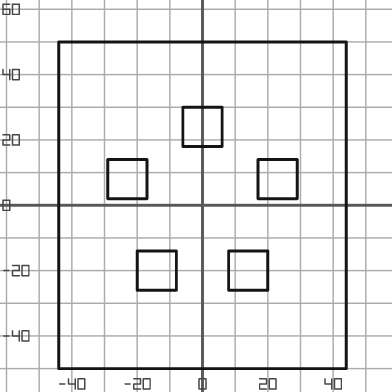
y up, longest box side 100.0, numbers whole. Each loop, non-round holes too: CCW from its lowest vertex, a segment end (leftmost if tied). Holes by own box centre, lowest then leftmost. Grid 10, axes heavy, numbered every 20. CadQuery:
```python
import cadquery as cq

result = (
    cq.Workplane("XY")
    .moveTo(-44.0, -50.0)
    .lineTo(44.0, -50.0)
    .lineTo(44.0, 50.0)
    .lineTo(-44.0, 50.0)
    .close()
    .moveTo(-20.0, -26.0)
    .lineTo(-8.0, -26.0)
    .lineTo(-8.0, -14.0)
    .lineTo(-20.0, -14.0)
    .close()
    .moveTo(8.0, -26.0)
    .lineTo(20.0, -26.0)
    .lineTo(20.0, -14.0)
    .lineTo(8.0, -14.0)
    .close()
    .moveTo(-29.0, 2.0)
    .lineTo(-17.0, 2.0)
    .lineTo(-17.0, 14.0)
    .lineTo(-29.0, 14.0)
    .close()
    .moveTo(17.0, 2.0)
    .lineTo(29.0, 2.0)
    .lineTo(29.0, 14.0)
    .lineTo(17.0, 14.0)
    .close()
    .moveTo(-6.0, 18.0)
    .lineTo(6.0, 18.0)
    .lineTo(6.0, 30.0)
    .lineTo(-6.0, 30.0)
    .close()
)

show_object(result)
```